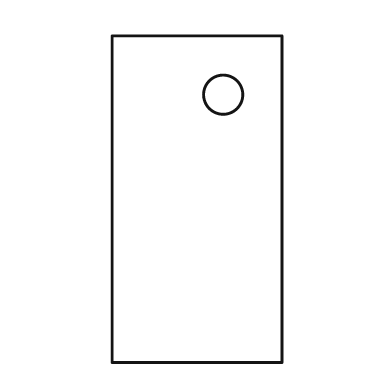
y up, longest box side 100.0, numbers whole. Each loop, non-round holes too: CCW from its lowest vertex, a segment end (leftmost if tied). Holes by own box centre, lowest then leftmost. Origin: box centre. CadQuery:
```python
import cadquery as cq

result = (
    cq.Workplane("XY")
    .moveTo(-26.0, -50.0)
    .lineTo(26.0, -50.0)
    .lineTo(26.0, 50.0)
    .lineTo(-26.0, 50.0)
    .close()
    .moveTo(8.0, 32.0)
    .circle(6.0)
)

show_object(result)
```